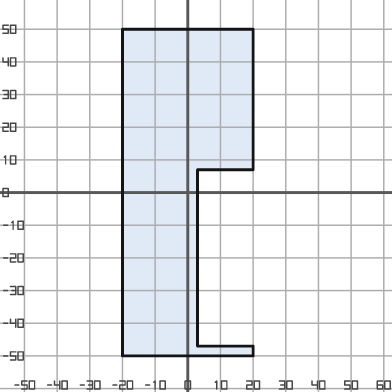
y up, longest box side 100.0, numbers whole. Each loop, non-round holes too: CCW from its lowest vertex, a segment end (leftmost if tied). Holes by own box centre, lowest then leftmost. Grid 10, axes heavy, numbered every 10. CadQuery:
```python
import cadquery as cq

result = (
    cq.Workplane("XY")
    .moveTo(-20.0, -50.0)
    .lineTo(20.0, -50.0)
    .lineTo(20.0, -47.0)
    .lineTo(3.0, -47.0)
    .lineTo(3.0, 7.0)
    .lineTo(20.0, 7.0)
    .lineTo(20.0, 50.0)
    .lineTo(-20.0, 50.0)
    .close()
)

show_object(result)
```